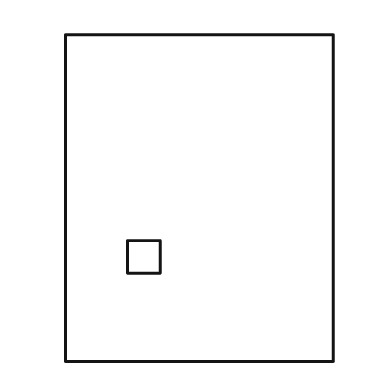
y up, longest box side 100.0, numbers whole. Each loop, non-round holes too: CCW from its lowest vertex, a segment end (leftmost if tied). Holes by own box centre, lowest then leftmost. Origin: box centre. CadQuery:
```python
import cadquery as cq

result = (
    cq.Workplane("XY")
    .moveTo(-41.0, -50.0)
    .lineTo(41.0, -50.0)
    .lineTo(41.0, 50.0)
    .lineTo(-41.0, 50.0)
    .close()
    .moveTo(-22.0, -23.0)
    .lineTo(-12.0, -23.0)
    .lineTo(-12.0, -13.0)
    .lineTo(-22.0, -13.0)
    .close()
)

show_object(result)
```